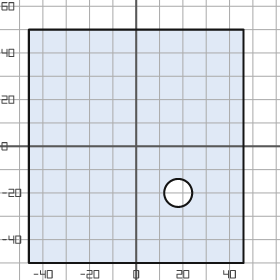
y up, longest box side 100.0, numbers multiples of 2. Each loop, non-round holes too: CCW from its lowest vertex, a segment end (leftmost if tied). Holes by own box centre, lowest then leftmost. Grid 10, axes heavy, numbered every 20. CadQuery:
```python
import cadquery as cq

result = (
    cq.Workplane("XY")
    .moveTo(-46.0, -50.0)
    .lineTo(46.0, -50.0)
    .lineTo(46.0, 50.0)
    .lineTo(-46.0, 50.0)
    .close()
    .moveTo(18.0, -20.0)
    .circle(6.0)
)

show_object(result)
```